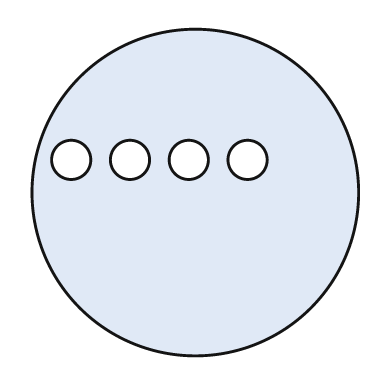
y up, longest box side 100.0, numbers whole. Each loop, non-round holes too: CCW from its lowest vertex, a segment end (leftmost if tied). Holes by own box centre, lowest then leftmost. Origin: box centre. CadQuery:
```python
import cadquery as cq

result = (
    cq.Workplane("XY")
    .moveTo(0.0, 0.0)
    .circle(50.0)
    .moveTo(-38.0, 10.0)
    .circle(6.0)
    .moveTo(-20.0, 10.0)
    .circle(6.0)
    .moveTo(-2.0, 10.0)
    .circle(6.0)
    .moveTo(16.0, 10.0)
    .circle(6.0)
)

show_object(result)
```